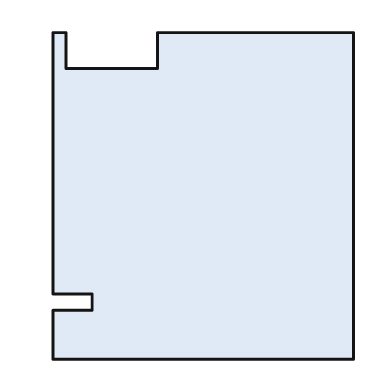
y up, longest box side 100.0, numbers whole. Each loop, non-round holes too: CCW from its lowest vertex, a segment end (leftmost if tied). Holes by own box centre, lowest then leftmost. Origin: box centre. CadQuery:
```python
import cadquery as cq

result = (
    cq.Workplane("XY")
    .moveTo(-46.0, -50.0)
    .lineTo(46.0, -50.0)
    .lineTo(46.0, 50.0)
    .lineTo(-14.0, 50.0)
    .lineTo(-14.0, 39.0)
    .lineTo(-42.0, 39.0)
    .lineTo(-42.0, 50.0)
    .lineTo(-46.0, 50.0)
    .lineTo(-46.0, -30.0)
    .lineTo(-34.0, -30.0)
    .lineTo(-34.0, -35.0)
    .lineTo(-46.0, -35.0)
    .close()
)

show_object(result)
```